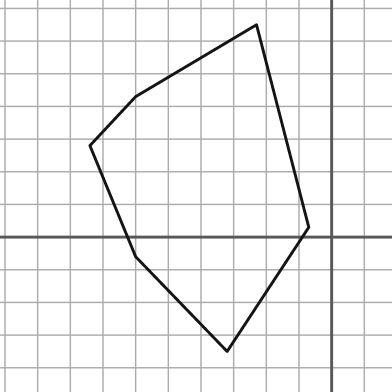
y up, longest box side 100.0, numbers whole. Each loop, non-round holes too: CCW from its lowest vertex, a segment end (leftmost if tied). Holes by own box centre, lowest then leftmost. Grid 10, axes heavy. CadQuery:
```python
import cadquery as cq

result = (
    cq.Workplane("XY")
    .moveTo(-32.0, -35.0)
    .lineTo(-7.0, 3.0)
    .lineTo(-23.0, 65.0)
    .lineTo(-60.0, 43.0)
    .lineTo(-74.0, 28.0)
    .lineTo(-60.0, -6.0)
    .close()
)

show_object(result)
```